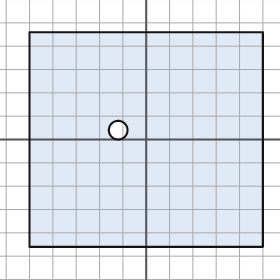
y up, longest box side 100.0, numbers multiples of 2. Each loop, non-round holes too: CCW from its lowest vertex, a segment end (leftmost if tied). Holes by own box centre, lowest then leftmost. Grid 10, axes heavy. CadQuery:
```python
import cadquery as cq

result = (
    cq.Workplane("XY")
    .moveTo(-50.0, -46.0)
    .lineTo(50.0, -46.0)
    .lineTo(50.0, 46.0)
    .lineTo(-50.0, 46.0)
    .close()
    .moveTo(-12.0, 4.0)
    .circle(4.0)
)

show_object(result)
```